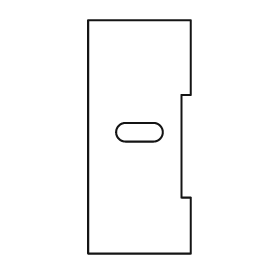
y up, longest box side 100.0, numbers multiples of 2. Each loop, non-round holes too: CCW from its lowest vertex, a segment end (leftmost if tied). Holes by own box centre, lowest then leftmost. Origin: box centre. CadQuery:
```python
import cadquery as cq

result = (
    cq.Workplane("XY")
    .moveTo(-22.0, -50.0)
    .lineTo(22.0, -50.0)
    .lineTo(22.0, -26.0)
    .lineTo(18.0, -26.0)
    .lineTo(18.0, 18.0)
    .lineTo(22.0, 18.0)
    .lineTo(22.0, 50.0)
    .lineTo(-22.0, 50.0)
    .close()
    .moveTo(-6.0, -2.0)
    .lineTo(6.0, -2.0)
    .threePointArc((10.0, 2.0), (6.0, 6.0))
    .lineTo(-6.0, 6.0)
    .threePointArc((-10.0, 2.0), (-6.0, -2.0))
    .close()
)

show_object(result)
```